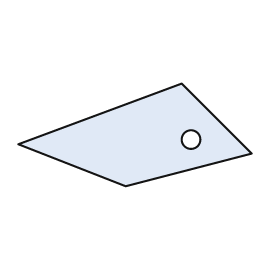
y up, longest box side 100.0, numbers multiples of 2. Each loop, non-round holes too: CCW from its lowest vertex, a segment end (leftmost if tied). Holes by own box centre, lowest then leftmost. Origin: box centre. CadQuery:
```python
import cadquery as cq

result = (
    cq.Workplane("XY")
    .moveTo(-4.0, -22.0)
    .lineTo(50.0, -8.0)
    .lineTo(20.0, 22.0)
    .lineTo(-50.0, -4.0)
    .close()
    .moveTo(24.0, -2.0)
    .circle(4.0)
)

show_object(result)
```